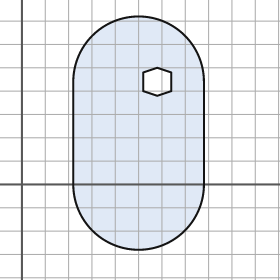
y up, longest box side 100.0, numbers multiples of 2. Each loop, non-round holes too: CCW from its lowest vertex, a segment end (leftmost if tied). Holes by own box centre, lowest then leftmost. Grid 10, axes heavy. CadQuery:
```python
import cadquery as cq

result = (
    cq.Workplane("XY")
    .moveTo(22.0, 0.0)
    .threePointArc((50.0, -28.0), (78.0, 0.0))
    .lineTo(78.0, 44.0)
    .threePointArc((50.0, 72.0), (22.0, 44.0))
    .close()
    .moveTo(58.0, 38.0)
    .lineTo(64.0, 40.0)
    .lineTo(64.0, 48.0)
    .lineTo(58.0, 50.0)
    .lineTo(52.0, 48.0)
    .lineTo(52.0, 40.0)
    .close()
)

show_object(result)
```